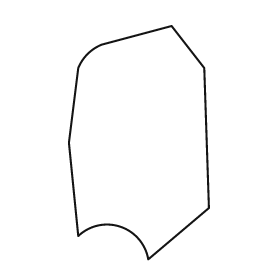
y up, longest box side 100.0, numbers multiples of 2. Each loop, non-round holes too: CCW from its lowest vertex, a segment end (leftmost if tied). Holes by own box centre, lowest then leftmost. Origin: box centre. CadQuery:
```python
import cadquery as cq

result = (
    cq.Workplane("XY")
    .moveTo(4.0, -50.0)
    .lineTo(30.0, -28.0)
    .lineTo(28.0, 32.0)
    .lineTo(14.0, 50.0)
    .lineTo(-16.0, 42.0)
    .threePointArc((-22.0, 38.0), (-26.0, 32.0))
    .lineTo(-30.0, 0.0)
    .lineTo(-26.0, -40.0)
    .threePointArc((-8.0, -36.0), (4.0, -50.0))
    .close()
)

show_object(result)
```